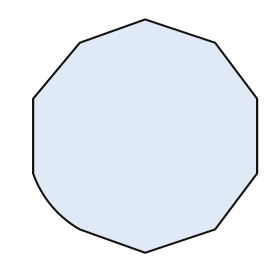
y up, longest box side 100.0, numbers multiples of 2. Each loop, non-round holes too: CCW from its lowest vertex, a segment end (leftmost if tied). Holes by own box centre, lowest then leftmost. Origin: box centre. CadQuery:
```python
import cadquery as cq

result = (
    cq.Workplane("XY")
    .moveTo(0.0, -50.0)
    .lineTo(30.0, -40.0)
    .lineTo(48.0, -16.0)
    .lineTo(48.0, 16.0)
    .lineTo(30.0, 40.0)
    .lineTo(0.0, 50.0)
    .lineTo(-28.0, 40.0)
    .lineTo(-48.0, 16.0)
    .lineTo(-48.0, -16.0)
    .threePointArc((-40.0, -30.0), (-28.0, -40.0))
    .close()
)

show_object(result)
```